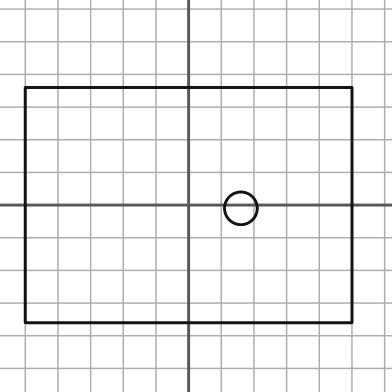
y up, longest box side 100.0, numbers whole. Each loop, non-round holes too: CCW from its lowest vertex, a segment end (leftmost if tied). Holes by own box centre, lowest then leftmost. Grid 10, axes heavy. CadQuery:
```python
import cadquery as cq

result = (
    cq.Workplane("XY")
    .moveTo(-50.0, -36.0)
    .lineTo(50.0, -36.0)
    .lineTo(50.0, 36.0)
    .lineTo(-50.0, 36.0)
    .close()
    .moveTo(16.0, -1.0)
    .circle(5.0)
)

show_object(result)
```